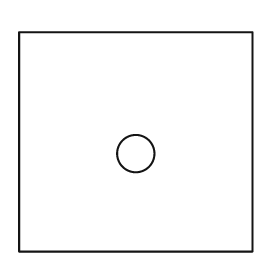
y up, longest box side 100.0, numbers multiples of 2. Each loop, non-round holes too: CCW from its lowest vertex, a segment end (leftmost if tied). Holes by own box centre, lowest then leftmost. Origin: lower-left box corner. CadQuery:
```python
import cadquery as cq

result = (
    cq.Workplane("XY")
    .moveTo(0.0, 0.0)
    .lineTo(100.0, 0.0)
    .lineTo(100.0, 94.0)
    .lineTo(0.0, 94.0)
    .close()
    .moveTo(50.0, 42.0)
    .circle(8.0)
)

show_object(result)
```